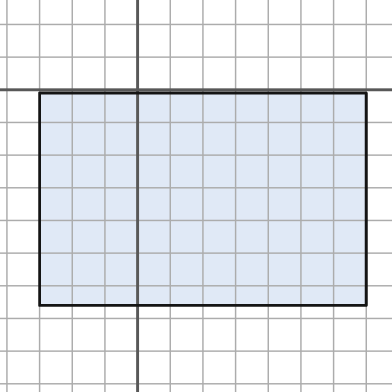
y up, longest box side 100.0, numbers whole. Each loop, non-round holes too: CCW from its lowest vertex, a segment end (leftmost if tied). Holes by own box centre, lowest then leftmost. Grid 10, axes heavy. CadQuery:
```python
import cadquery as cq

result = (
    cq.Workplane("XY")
    .moveTo(-30.0, -66.0)
    .lineTo(70.0, -66.0)
    .lineTo(70.0, -1.0)
    .lineTo(-30.0, -1.0)
    .close()
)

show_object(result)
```